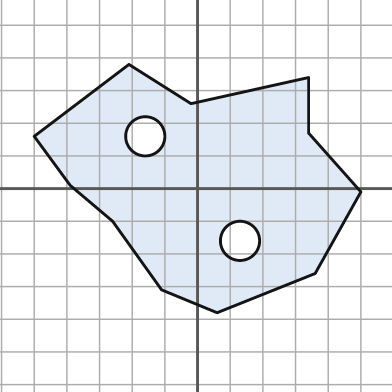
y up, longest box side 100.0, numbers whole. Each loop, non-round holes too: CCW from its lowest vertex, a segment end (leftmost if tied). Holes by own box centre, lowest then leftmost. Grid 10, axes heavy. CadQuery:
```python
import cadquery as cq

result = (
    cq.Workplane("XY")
    .moveTo(6.0, -38.0)
    .lineTo(36.0, -26.0)
    .lineTo(50.0, -1.0)
    .lineTo(34.0, 17.0)
    .lineTo(34.0, 34.0)
    .lineTo(-2.0, 26.0)
    .lineTo(-21.0, 38.0)
    .lineTo(-50.0, 16.0)
    .lineTo(-39.0, 1.0)
    .lineTo(-26.0, -10.0)
    .lineTo(-11.0, -31.0)
    .close()
    .moveTo(13.0, -16.0)
    .circle(6.0)
    .moveTo(-16.0, 16.0)
    .circle(6.0)
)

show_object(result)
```